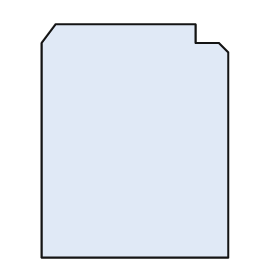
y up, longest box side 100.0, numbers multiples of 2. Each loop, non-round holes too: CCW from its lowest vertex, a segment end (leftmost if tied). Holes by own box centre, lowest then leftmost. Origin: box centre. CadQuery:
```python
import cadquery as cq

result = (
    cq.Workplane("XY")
    .moveTo(-40.0, -50.0)
    .lineTo(40.0, -50.0)
    .lineTo(40.0, 38.0)
    .lineTo(36.0, 42.0)
    .lineTo(26.0, 42.0)
    .lineTo(26.0, 50.0)
    .lineTo(-34.0, 50.0)
    .lineTo(-40.0, 42.0)
    .close()
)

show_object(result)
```